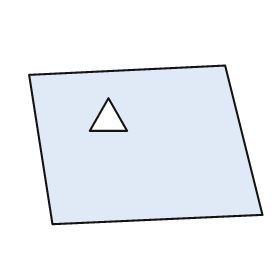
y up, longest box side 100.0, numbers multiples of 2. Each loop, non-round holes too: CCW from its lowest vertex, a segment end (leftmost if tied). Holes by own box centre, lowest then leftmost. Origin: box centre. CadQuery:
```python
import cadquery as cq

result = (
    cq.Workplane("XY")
    .moveTo(-40.0, -34.0)
    .lineTo(50.0, -30.0)
    .lineTo(34.0, 34.0)
    .lineTo(-50.0, 30.0)
    .close()
    .moveTo(-24.0, 6.0)
    .lineTo(-8.0, 6.0)
    .lineTo(-16.0, 20.0)
    .close()
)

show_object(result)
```